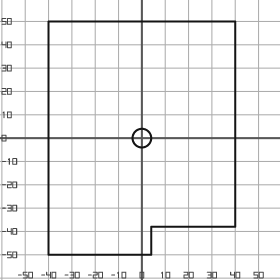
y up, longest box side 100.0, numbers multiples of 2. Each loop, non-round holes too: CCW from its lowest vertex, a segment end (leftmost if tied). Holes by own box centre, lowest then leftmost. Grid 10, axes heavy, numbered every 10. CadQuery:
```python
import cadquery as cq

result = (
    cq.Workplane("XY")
    .moveTo(-40.0, -50.0)
    .lineTo(4.0, -50.0)
    .lineTo(4.0, -38.0)
    .lineTo(40.0, -38.0)
    .lineTo(40.0, 50.0)
    .lineTo(-40.0, 50.0)
    .close()
    .moveTo(0.0, 0.0)
    .circle(4.0)
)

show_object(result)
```